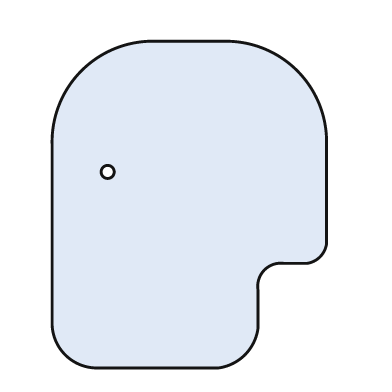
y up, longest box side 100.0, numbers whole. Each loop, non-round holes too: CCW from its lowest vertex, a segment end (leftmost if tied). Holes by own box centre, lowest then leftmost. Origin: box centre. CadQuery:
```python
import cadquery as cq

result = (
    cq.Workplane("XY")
    .moveTo(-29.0, -50.0)
    .lineTo(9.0, -50.0)
    .threePointArc((17.0, -46.0), (21.0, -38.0))
    .lineTo(21.0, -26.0)
    .threePointArc((23.0, -20.0), (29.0, -18.0))
    .lineTo(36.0, -18.0)
    .threePointArc((40.0, -16.0), (42.0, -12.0))
    .lineTo(42.0, 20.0)
    .threePointArc((33.0, 41.0), (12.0, 50.0))
    .lineTo(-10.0, 50.0)
    .threePointArc((-33.0, 41.0), (-42.0, 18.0))
    .lineTo(-42.0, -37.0)
    .threePointArc((-38.0, -46.0), (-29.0, -50.0))
    .close()
    .moveTo(-25.0, 10.0)
    .circle(2.0)
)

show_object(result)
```